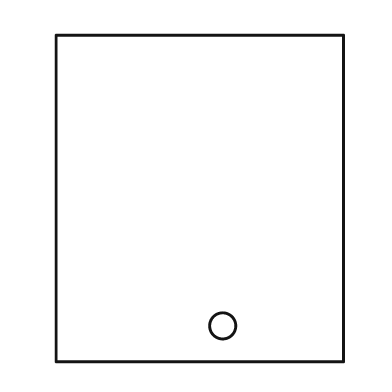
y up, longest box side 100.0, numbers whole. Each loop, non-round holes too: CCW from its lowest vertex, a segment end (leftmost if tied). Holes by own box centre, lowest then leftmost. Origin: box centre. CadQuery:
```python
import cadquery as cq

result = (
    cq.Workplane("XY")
    .moveTo(-44.0, -50.0)
    .lineTo(44.0, -50.0)
    .lineTo(44.0, 50.0)
    .lineTo(-44.0, 50.0)
    .close()
    .moveTo(7.0, -39.0)
    .circle(4.0)
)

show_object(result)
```